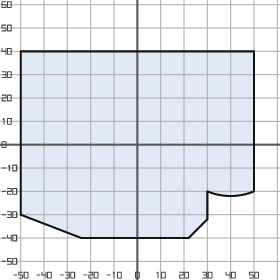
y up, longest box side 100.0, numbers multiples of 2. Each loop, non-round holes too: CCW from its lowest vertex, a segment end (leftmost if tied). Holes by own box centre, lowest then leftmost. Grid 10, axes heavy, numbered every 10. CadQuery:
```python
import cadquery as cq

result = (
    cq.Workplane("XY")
    .moveTo(-24.0, -40.0)
    .lineTo(22.0, -40.0)
    .lineTo(30.0, -32.0)
    .lineTo(30.0, -20.0)
    .threePointArc((40.0, -22.0), (50.0, -20.0))
    .lineTo(50.0, 40.0)
    .lineTo(-50.0, 40.0)
    .lineTo(-50.0, -30.0)
    .close()
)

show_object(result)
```